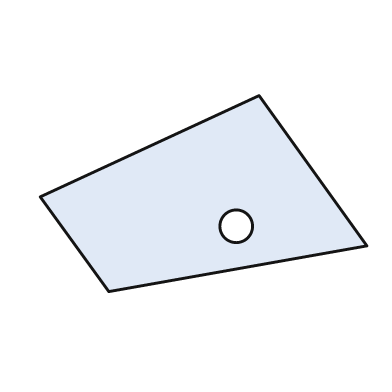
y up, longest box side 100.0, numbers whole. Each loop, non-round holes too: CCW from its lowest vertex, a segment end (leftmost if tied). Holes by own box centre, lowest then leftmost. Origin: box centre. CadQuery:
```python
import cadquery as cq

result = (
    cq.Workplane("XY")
    .moveTo(-29.0, -30.0)
    .lineTo(50.0, -16.0)
    .lineTo(17.0, 30.0)
    .lineTo(-50.0, -1.0)
    .close()
    .moveTo(10.0, -10.0)
    .circle(5.0)
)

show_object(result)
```